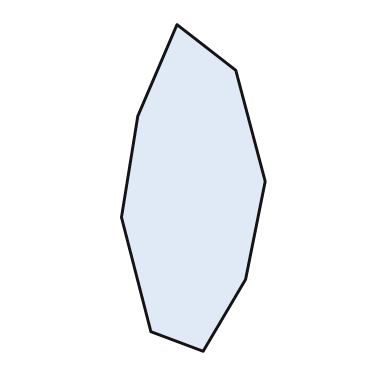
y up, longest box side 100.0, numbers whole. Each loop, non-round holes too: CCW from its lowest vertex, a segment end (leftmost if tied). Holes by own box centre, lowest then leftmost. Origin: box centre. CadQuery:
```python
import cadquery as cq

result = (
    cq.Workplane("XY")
    .moveTo(3.0, -50.0)
    .lineTo(16.0, -28.0)
    .lineTo(22.0, 2.0)
    .lineTo(13.0, 36.0)
    .lineTo(-5.0, 50.0)
    .lineTo(-17.0, 22.0)
    .lineTo(-22.0, -9.0)
    .lineTo(-13.0, -44.0)
    .close()
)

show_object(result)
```